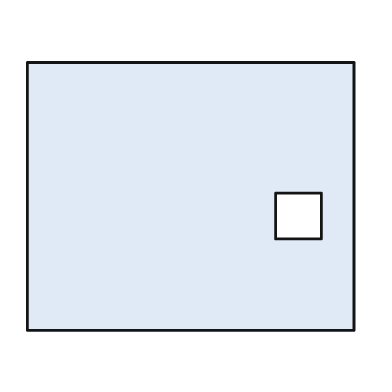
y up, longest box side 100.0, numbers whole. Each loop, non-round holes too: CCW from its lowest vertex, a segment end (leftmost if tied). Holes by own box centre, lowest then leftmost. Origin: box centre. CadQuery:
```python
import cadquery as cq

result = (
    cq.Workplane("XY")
    .moveTo(-50.0, -41.0)
    .lineTo(50.0, -41.0)
    .lineTo(50.0, 41.0)
    .lineTo(-50.0, 41.0)
    .close()
    .moveTo(26.0, -13.0)
    .lineTo(40.0, -13.0)
    .lineTo(40.0, 1.0)
    .lineTo(26.0, 1.0)
    .close()
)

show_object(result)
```